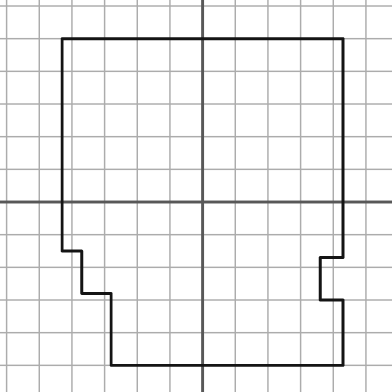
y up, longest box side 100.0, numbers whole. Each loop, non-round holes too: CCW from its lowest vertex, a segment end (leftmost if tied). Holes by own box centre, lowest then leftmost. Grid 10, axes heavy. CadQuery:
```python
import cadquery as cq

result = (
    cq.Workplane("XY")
    .moveTo(-28.0, -50.0)
    .lineTo(43.0, -50.0)
    .lineTo(43.0, -30.0)
    .lineTo(36.0, -30.0)
    .lineTo(36.0, -17.0)
    .lineTo(43.0, -17.0)
    .lineTo(43.0, 50.0)
    .lineTo(-43.0, 50.0)
    .lineTo(-43.0, -15.0)
    .lineTo(-37.0, -15.0)
    .lineTo(-37.0, -28.0)
    .lineTo(-28.0, -28.0)
    .close()
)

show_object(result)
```